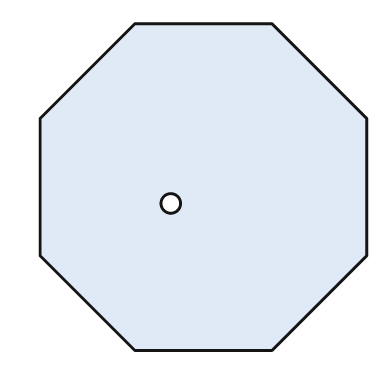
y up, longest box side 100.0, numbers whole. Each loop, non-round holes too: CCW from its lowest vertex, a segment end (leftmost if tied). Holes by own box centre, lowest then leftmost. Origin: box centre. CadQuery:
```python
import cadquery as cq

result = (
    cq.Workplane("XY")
    .moveTo(-21.0, -50.0)
    .lineTo(21.0, -50.0)
    .lineTo(50.0, -21.0)
    .lineTo(50.0, 21.0)
    .lineTo(21.0, 50.0)
    .lineTo(-21.0, 50.0)
    .lineTo(-50.0, 21.0)
    .lineTo(-50.0, -21.0)
    .close()
    .moveTo(-10.0, -5.0)
    .circle(3.0)
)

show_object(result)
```